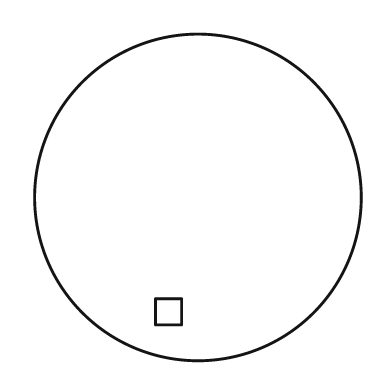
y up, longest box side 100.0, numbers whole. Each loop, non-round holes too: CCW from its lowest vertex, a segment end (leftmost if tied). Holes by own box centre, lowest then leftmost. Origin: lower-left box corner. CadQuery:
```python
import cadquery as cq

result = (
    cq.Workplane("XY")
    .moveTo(50.0, 50.0)
    .circle(50.0)
    .moveTo(37.0, 11.0)
    .lineTo(45.0, 11.0)
    .lineTo(45.0, 19.0)
    .lineTo(37.0, 19.0)
    .close()
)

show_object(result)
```